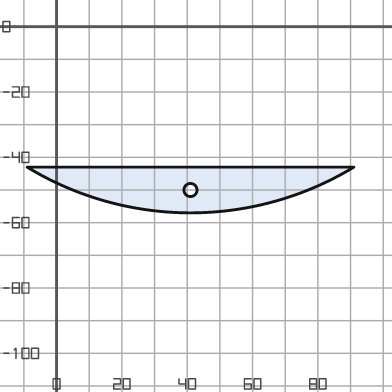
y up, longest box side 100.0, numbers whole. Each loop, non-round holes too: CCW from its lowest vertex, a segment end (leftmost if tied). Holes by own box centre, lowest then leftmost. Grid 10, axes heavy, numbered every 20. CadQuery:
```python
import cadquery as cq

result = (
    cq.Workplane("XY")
    .moveTo(-9.0, -43.0)
    .threePointArc((41.0, -57.0), (91.0, -43.0))
    .close()
    .moveTo(41.0, -50.0)
    .circle(2.0)
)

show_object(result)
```